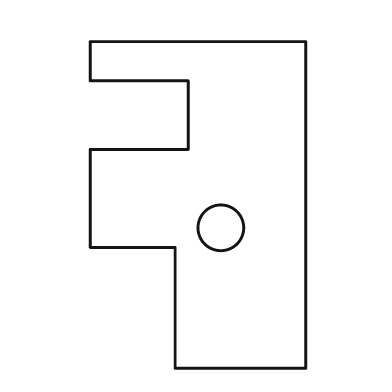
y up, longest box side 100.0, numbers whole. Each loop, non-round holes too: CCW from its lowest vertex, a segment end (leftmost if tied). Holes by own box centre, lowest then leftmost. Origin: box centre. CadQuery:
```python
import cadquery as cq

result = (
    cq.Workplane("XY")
    .moveTo(-7.0, -50.0)
    .lineTo(33.0, -50.0)
    .lineTo(33.0, 50.0)
    .lineTo(-33.0, 50.0)
    .lineTo(-33.0, 38.0)
    .lineTo(-3.0, 38.0)
    .lineTo(-3.0, 17.0)
    .lineTo(-33.0, 17.0)
    .lineTo(-33.0, -13.0)
    .lineTo(-7.0, -13.0)
    .close()
    .moveTo(7.0, -7.0)
    .circle(7.0)
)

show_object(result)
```